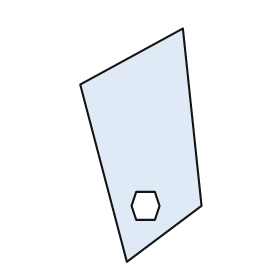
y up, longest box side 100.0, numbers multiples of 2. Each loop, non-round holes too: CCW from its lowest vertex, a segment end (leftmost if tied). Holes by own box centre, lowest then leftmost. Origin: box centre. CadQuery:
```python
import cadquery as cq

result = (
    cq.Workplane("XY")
    .moveTo(-6.0, -50.0)
    .lineTo(26.0, -26.0)
    .lineTo(18.0, 50.0)
    .lineTo(-26.0, 26.0)
    .close()
    .moveTo(-2.0, -32.0)
    .lineTo(6.0, -32.0)
    .lineTo(8.0, -26.0)
    .lineTo(6.0, -20.0)
    .lineTo(-2.0, -20.0)
    .lineTo(-4.0, -26.0)
    .close()
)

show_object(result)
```